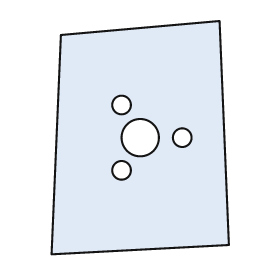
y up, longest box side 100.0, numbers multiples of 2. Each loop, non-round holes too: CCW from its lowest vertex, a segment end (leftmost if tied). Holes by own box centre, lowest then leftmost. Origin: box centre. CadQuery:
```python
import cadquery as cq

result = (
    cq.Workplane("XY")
    .moveTo(-38.0, -50.0)
    .lineTo(38.0, -46.0)
    .lineTo(34.0, 50.0)
    .lineTo(-34.0, 44.0)
    .close()
    .moveTo(-8.0, -14.0)
    .circle(4.0)
    .moveTo(0.0, 0.0)
    .circle(8.0)
    .moveTo(18.0, 0.0)
    .circle(4.0)
    .moveTo(-8.0, 14.0)
    .circle(4.0)
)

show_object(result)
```